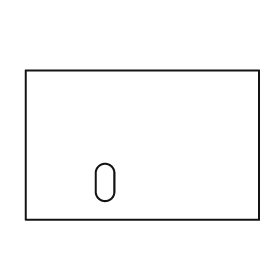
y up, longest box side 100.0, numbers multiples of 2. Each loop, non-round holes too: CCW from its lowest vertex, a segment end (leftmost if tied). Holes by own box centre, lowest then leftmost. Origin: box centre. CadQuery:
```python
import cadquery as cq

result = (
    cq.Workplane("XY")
    .moveTo(-50.0, -32.0)
    .lineTo(50.0, -32.0)
    .lineTo(50.0, 32.0)
    .lineTo(-50.0, 32.0)
    .close()
    .moveTo(-20.0, -20.0)
    .threePointArc((-16.0, -24.0), (-12.0, -20.0))
    .lineTo(-12.0, -12.0)
    .threePointArc((-16.0, -8.0), (-20.0, -12.0))
    .close()
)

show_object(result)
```